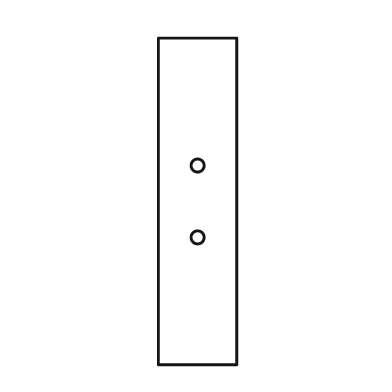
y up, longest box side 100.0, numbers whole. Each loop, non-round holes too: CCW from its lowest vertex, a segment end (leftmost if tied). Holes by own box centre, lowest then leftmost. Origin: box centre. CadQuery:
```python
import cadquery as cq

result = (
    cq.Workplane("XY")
    .moveTo(-12.0, -50.0)
    .lineTo(12.0, -50.0)
    .lineTo(12.0, 50.0)
    .lineTo(-12.0, 50.0)
    .close()
    .moveTo(0.0, -11.0)
    .circle(2.0)
    .moveTo(0.0, 11.0)
    .circle(2.0)
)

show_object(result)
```